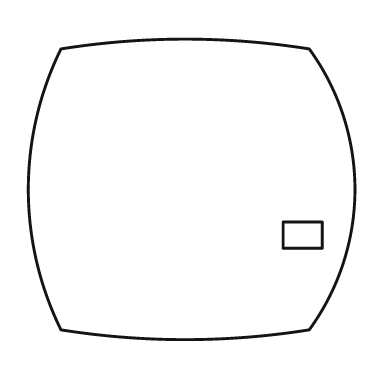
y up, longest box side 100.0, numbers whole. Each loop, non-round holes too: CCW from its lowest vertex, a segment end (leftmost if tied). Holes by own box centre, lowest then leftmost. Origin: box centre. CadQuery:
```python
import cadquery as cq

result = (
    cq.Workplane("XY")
    .moveTo(-40.0, -43.0)
    .threePointArc((-2.0, -46.0), (36.0, -43.0))
    .threePointArc((50.0, 0.0), (36.0, 43.0))
    .threePointArc((-2.0, 46.0), (-40.0, 43.0))
    .threePointArc((-50.0, 0.0), (-40.0, -43.0))
    .close()
    .moveTo(28.0, -18.0)
    .lineTo(40.0, -18.0)
    .lineTo(40.0, -10.0)
    .lineTo(28.0, -10.0)
    .close()
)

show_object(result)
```